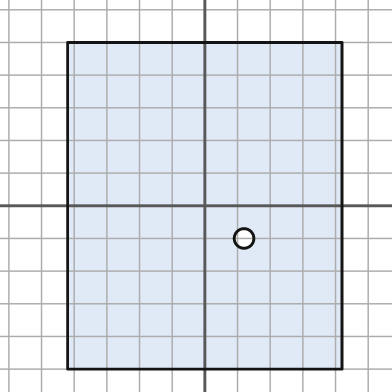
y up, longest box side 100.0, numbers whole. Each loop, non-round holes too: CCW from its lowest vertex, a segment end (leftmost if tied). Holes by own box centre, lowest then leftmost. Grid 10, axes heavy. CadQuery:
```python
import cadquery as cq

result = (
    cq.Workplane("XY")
    .moveTo(-42.0, -50.0)
    .lineTo(42.0, -50.0)
    .lineTo(42.0, 50.0)
    .lineTo(-42.0, 50.0)
    .close()
    .moveTo(12.0, -10.0)
    .circle(3.0)
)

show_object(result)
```